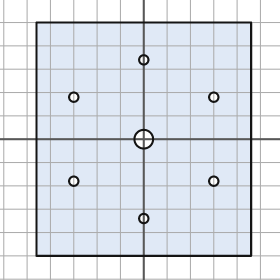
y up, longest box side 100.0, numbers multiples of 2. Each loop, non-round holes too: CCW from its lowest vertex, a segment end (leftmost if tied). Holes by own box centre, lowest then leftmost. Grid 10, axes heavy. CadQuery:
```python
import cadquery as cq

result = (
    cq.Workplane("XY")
    .moveTo(-46.0, -50.0)
    .lineTo(46.0, -50.0)
    .lineTo(46.0, 50.0)
    .lineTo(-46.0, 50.0)
    .close()
    .moveTo(0.0, -34.0)
    .circle(2.0)
    .moveTo(-30.0, -18.0)
    .circle(2.0)
    .moveTo(30.0, -18.0)
    .circle(2.0)
    .moveTo(0.0, 0.0)
    .circle(4.0)
    .moveTo(-30.0, 18.0)
    .circle(2.0)
    .moveTo(30.0, 18.0)
    .circle(2.0)
    .moveTo(0.0, 34.0)
    .circle(2.0)
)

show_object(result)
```